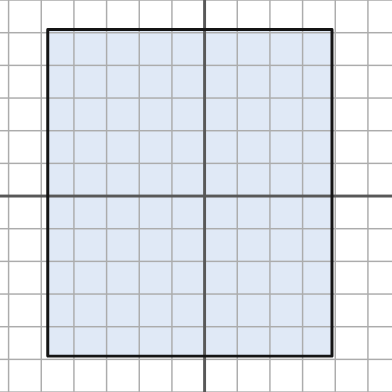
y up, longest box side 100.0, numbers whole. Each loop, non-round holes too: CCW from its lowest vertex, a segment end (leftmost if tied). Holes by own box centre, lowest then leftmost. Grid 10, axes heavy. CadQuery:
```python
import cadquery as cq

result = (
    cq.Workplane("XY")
    .moveTo(-48.0, -49.0)
    .lineTo(39.0, -49.0)
    .lineTo(39.0, 51.0)
    .lineTo(-48.0, 51.0)
    .close()
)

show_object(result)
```